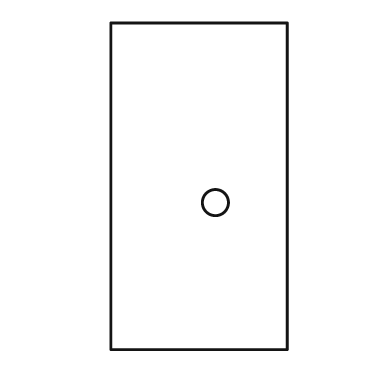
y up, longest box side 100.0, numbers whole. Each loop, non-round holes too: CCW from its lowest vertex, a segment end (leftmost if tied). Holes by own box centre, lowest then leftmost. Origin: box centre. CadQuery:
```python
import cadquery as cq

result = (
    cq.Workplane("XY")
    .moveTo(-27.0, -50.0)
    .lineTo(27.0, -50.0)
    .lineTo(27.0, 50.0)
    .lineTo(-27.0, 50.0)
    .close()
    .moveTo(5.0, -5.0)
    .circle(4.0)
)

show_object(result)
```